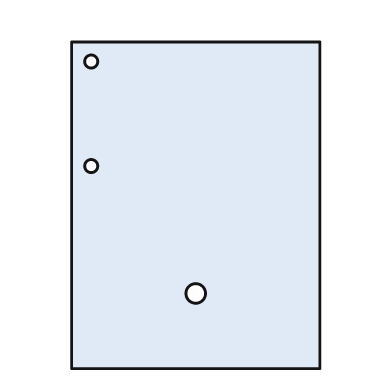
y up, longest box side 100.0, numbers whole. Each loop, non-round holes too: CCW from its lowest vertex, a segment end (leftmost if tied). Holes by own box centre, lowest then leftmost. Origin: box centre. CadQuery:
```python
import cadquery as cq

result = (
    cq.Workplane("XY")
    .moveTo(-38.0, -50.0)
    .lineTo(38.0, -50.0)
    .lineTo(38.0, 50.0)
    .lineTo(-38.0, 50.0)
    .close()
    .moveTo(0.0, -27.0)
    .circle(3.0)
    .moveTo(-32.0, 12.0)
    .circle(2.0)
    .moveTo(-32.0, 44.0)
    .circle(2.0)
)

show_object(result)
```